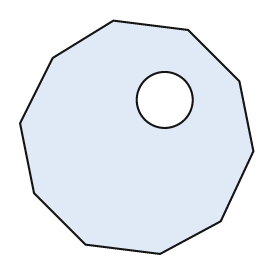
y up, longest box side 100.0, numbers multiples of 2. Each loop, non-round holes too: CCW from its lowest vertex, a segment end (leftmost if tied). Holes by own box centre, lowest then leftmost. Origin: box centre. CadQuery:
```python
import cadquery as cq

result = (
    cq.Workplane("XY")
    .moveTo(10.0, -50.0)
    .lineTo(36.0, -36.0)
    .lineTo(50.0, -6.0)
    .lineTo(44.0, 24.0)
    .lineTo(22.0, 46.0)
    .lineTo(-10.0, 50.0)
    .lineTo(-36.0, 34.0)
    .lineTo(-50.0, 6.0)
    .lineTo(-44.0, -24.0)
    .lineTo(-22.0, -46.0)
    .close()
    .moveTo(12.0, 16.0)
    .circle(12.0)
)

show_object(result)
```